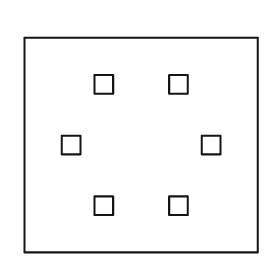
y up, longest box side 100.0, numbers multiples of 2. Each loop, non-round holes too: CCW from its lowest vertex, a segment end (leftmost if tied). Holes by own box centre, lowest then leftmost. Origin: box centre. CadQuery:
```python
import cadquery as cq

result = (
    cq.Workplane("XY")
    .moveTo(-50.0, -46.0)
    .lineTo(50.0, -46.0)
    .lineTo(50.0, 46.0)
    .lineTo(-50.0, 46.0)
    .close()
    .moveTo(-20.0, -30.0)
    .lineTo(-12.0, -30.0)
    .lineTo(-12.0, -22.0)
    .lineTo(-20.0, -22.0)
    .close()
    .moveTo(12.0, -30.0)
    .lineTo(20.0, -30.0)
    .lineTo(20.0, -22.0)
    .lineTo(12.0, -22.0)
    .close()
    .moveTo(-34.0, -4.0)
    .lineTo(-26.0, -4.0)
    .lineTo(-26.0, 4.0)
    .lineTo(-34.0, 4.0)
    .close()
    .moveTo(26.0, -4.0)
    .lineTo(34.0, -4.0)
    .lineTo(34.0, 4.0)
    .lineTo(26.0, 4.0)
    .close()
    .moveTo(-20.0, 22.0)
    .lineTo(-12.0, 22.0)
    .lineTo(-12.0, 30.0)
    .lineTo(-20.0, 30.0)
    .close()
    .moveTo(12.0, 22.0)
    .lineTo(20.0, 22.0)
    .lineTo(20.0, 30.0)
    .lineTo(12.0, 30.0)
    .close()
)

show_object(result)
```